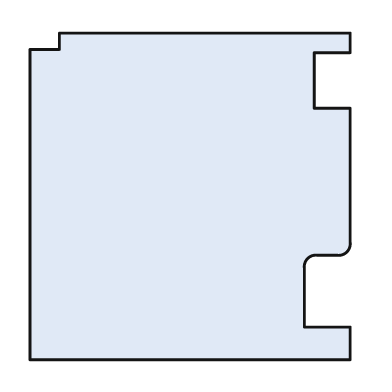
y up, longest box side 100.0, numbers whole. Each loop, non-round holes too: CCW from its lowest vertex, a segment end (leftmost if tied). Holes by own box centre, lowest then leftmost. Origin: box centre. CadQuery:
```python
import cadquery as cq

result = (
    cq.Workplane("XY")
    .moveTo(-49.0, -50.0)
    .lineTo(49.0, -50.0)
    .lineTo(49.0, -40.0)
    .lineTo(35.0, -40.0)
    .lineTo(35.0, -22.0)
    .threePointArc((36.0, -19.0), (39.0, -18.0))
    .lineTo(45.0, -18.0)
    .threePointArc((48.0, -17.0), (49.0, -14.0))
    .lineTo(49.0, 27.0)
    .lineTo(38.0, 27.0)
    .lineTo(38.0, 44.0)
    .lineTo(49.0, 44.0)
    .lineTo(49.0, 50.0)
    .lineTo(-40.0, 50.0)
    .lineTo(-40.0, 45.0)
    .lineTo(-49.0, 45.0)
    .close()
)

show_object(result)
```